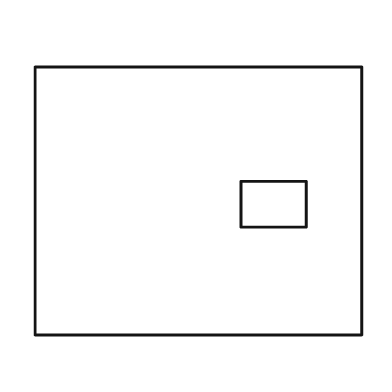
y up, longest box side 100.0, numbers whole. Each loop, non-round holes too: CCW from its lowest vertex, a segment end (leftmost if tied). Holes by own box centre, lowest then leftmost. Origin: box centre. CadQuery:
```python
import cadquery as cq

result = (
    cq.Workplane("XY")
    .moveTo(-50.0, -41.0)
    .lineTo(50.0, -41.0)
    .lineTo(50.0, 41.0)
    .lineTo(-50.0, 41.0)
    .close()
    .moveTo(13.0, -8.0)
    .lineTo(33.0, -8.0)
    .lineTo(33.0, 6.0)
    .lineTo(13.0, 6.0)
    .close()
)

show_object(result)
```